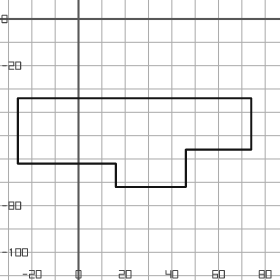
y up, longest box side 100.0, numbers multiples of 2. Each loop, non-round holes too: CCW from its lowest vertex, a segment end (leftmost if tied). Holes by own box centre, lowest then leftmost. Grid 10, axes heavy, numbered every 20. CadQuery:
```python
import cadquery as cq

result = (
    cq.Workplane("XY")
    .moveTo(16.0, -72.0)
    .lineTo(46.0, -72.0)
    .lineTo(46.0, -56.0)
    .lineTo(74.0, -56.0)
    .lineTo(74.0, -34.0)
    .lineTo(-26.0, -34.0)
    .lineTo(-26.0, -62.0)
    .lineTo(16.0, -62.0)
    .close()
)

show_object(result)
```